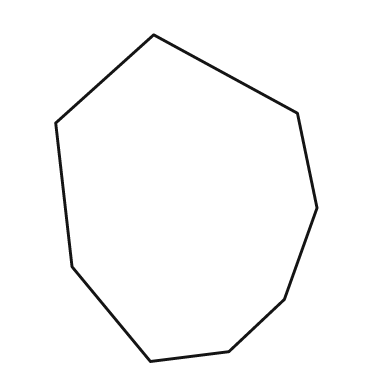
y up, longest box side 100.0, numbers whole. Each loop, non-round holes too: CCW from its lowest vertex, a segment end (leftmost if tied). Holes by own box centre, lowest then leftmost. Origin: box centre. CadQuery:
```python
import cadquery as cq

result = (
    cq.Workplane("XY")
    .moveTo(-11.0, -50.0)
    .lineTo(13.0, -47.0)
    .lineTo(30.0, -31.0)
    .lineTo(40.0, -3.0)
    .lineTo(34.0, 26.0)
    .lineTo(-10.0, 50.0)
    .lineTo(-40.0, 23.0)
    .lineTo(-35.0, -21.0)
    .close()
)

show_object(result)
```